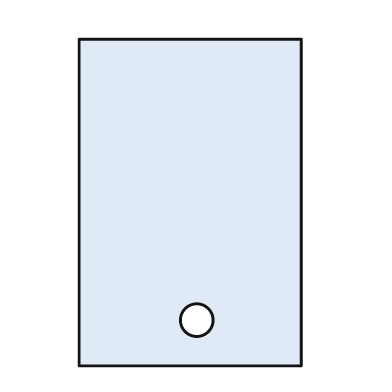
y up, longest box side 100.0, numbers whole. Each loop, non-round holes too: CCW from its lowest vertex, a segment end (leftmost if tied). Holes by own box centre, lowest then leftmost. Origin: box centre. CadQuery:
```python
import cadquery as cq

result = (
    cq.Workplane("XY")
    .moveTo(-34.0, -50.0)
    .lineTo(34.0, -50.0)
    .lineTo(34.0, 50.0)
    .lineTo(-34.0, 50.0)
    .close()
    .moveTo(2.0, -36.0)
    .circle(5.0)
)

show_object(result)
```